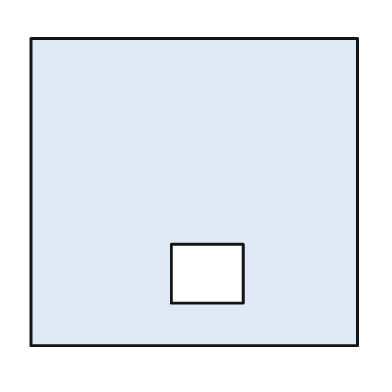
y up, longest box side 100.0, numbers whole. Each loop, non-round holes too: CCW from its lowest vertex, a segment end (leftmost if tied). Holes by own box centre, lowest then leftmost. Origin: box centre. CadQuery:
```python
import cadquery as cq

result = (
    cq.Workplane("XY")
    .moveTo(-50.0, -47.0)
    .lineTo(50.0, -47.0)
    .lineTo(50.0, 47.0)
    .lineTo(-50.0, 47.0)
    .close()
    .moveTo(-7.0, -34.0)
    .lineTo(15.0, -34.0)
    .lineTo(15.0, -16.0)
    .lineTo(-7.0, -16.0)
    .close()
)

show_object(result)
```